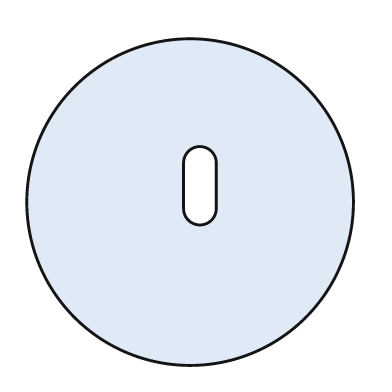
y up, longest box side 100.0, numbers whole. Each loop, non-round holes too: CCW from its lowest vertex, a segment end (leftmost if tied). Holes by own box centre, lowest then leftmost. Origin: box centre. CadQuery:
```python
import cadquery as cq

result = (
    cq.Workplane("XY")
    .moveTo(0.0, 0.0)
    .circle(50.0)
    .moveTo(-2.0, -2.0)
    .threePointArc((3.0, -7.0), (8.0, -2.0))
    .lineTo(8.0, 12.0)
    .threePointArc((3.0, 17.0), (-2.0, 12.0))
    .close()
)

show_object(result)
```